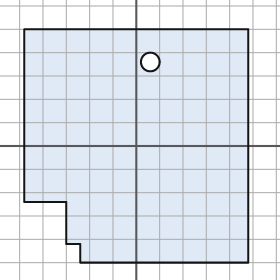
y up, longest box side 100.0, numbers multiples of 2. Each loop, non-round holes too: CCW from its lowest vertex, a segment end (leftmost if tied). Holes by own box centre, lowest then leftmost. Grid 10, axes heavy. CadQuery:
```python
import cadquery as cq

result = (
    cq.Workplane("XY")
    .moveTo(-24.0, -50.0)
    .lineTo(48.0, -50.0)
    .lineTo(48.0, 50.0)
    .lineTo(-48.0, 50.0)
    .lineTo(-48.0, -24.0)
    .lineTo(-30.0, -24.0)
    .lineTo(-30.0, -42.0)
    .lineTo(-24.0, -42.0)
    .close()
    .moveTo(6.0, 36.0)
    .circle(4.0)
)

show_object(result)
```